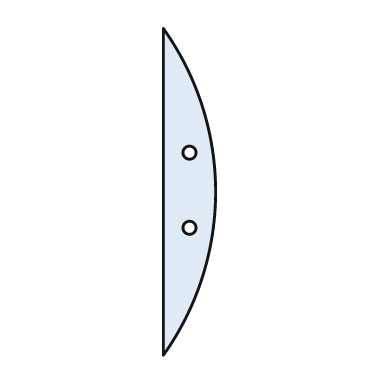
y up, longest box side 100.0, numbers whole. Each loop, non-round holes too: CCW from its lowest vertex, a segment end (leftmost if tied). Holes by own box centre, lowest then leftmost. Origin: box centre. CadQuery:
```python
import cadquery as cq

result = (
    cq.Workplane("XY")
    .moveTo(-8.0, -50.0)
    .threePointArc((8.0, 0.0), (-8.0, 50.0))
    .close()
    .moveTo(0.0, -11.0)
    .circle(2.0)
    .moveTo(0.0, 12.0)
    .circle(2.0)
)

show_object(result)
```